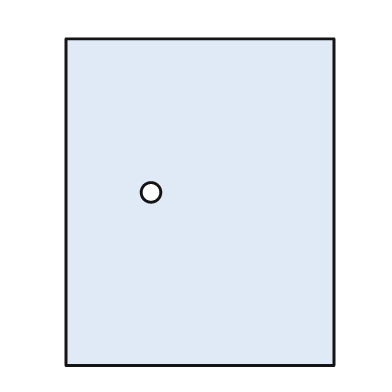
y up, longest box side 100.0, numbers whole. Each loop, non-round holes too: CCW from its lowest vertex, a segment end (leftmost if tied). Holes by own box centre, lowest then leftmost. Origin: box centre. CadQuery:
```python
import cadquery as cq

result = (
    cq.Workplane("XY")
    .moveTo(-41.0, -50.0)
    .lineTo(41.0, -50.0)
    .lineTo(41.0, 50.0)
    .lineTo(-41.0, 50.0)
    .close()
    .moveTo(-15.0, 3.0)
    .circle(3.0)
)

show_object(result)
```